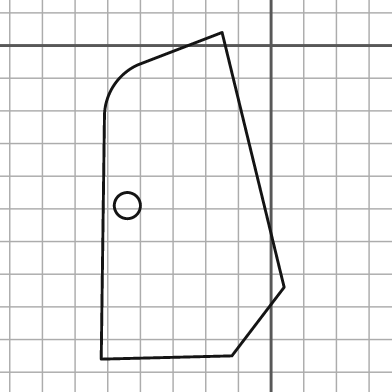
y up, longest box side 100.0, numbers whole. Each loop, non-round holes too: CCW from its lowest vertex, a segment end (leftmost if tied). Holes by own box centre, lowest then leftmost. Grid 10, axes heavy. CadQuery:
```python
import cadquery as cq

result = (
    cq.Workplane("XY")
    .moveTo(-52.0, -96.0)
    .lineTo(-12.0, -95.0)
    .lineTo(4.0, -74.0)
    .lineTo(-15.0, 4.0)
    .lineTo(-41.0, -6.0)
    .threePointArc((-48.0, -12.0), (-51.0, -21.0))
    .close()
    .moveTo(-44.0, -49.0)
    .circle(4.0)
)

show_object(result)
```